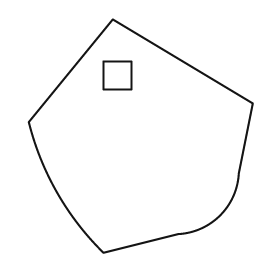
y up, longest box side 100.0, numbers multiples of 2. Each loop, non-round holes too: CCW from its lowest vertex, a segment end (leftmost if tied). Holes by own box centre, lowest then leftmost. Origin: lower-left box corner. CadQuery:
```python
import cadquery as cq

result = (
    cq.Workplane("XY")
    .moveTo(32.0, 0.0)
    .lineTo(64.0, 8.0)
    .threePointArc((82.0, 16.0), (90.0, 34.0))
    .lineTo(96.0, 64.0)
    .lineTo(36.0, 100.0)
    .lineTo(0.0, 56.0)
    .threePointArc((12.0, 26.0), (32.0, 0.0))
    .close()
    .moveTo(32.0, 70.0)
    .lineTo(44.0, 70.0)
    .lineTo(44.0, 82.0)
    .lineTo(32.0, 82.0)
    .close()
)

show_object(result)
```